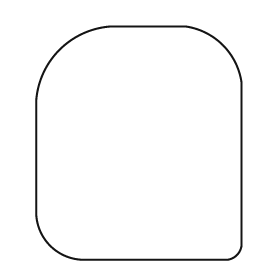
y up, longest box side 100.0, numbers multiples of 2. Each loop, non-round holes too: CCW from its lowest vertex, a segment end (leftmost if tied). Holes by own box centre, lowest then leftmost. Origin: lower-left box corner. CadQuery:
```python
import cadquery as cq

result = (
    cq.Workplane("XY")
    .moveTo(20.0, 0.0)
    .lineTo(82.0, 0.0)
    .threePointArc((86.0, 2.0), (88.0, 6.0))
    .lineTo(88.0, 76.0)
    .threePointArc((80.0, 92.0), (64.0, 100.0))
    .lineTo(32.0, 100.0)
    .threePointArc((10.0, 90.0), (0.0, 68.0))
    .lineTo(0.0, 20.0)
    .threePointArc((6.0, 6.0), (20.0, 0.0))
    .close()
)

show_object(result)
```